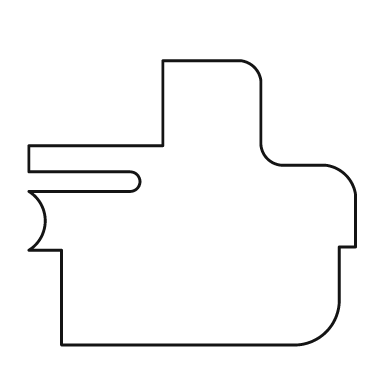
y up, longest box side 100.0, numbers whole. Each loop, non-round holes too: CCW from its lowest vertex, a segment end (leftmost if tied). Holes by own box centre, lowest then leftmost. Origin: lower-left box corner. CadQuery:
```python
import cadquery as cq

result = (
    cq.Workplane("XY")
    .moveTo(10.0, 0.0)
    .lineTo(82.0, 0.0)
    .threePointArc((91.0, 4.0), (95.0, 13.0))
    .lineTo(95.0, 30.0)
    .lineTo(100.0, 30.0)
    .lineTo(100.0, 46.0)
    .threePointArc((97.0, 52.0), (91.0, 55.0))
    .lineTo(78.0, 55.0)
    .threePointArc((73.0, 57.0), (71.0, 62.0))
    .lineTo(71.0, 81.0)
    .threePointArc((69.0, 85.0), (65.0, 87.0))
    .lineTo(41.0, 87.0)
    .lineTo(41.0, 61.0)
    .lineTo(0.0, 61.0)
    .lineTo(0.0, 53.0)
    .lineTo(31.0, 53.0)
    .threePointArc((34.0, 50.0), (31.0, 47.0))
    .lineTo(0.0, 47.0)
    .threePointArc((5.0, 38.0), (0.0, 29.0))
    .lineTo(10.0, 29.0)
    .close()
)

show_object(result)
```